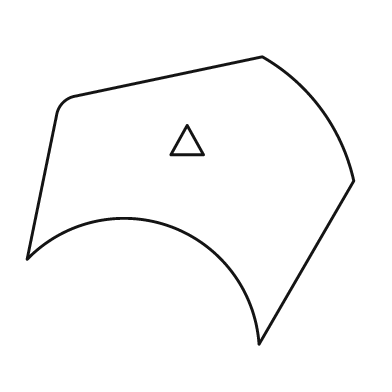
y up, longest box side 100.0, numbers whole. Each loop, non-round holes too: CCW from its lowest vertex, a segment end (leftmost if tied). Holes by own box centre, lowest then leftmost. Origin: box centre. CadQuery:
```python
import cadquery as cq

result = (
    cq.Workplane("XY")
    .moveTo(21.0, -44.0)
    .lineTo(50.0, 6.0)
    .threePointArc((40.0, 28.0), (22.0, 44.0))
    .lineTo(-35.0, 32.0)
    .threePointArc((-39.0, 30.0), (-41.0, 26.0))
    .lineTo(-50.0, -18.0)
    .threePointArc((-6.0, -8.0), (21.0, -44.0))
    .close()
    .moveTo(-6.0, 14.0)
    .lineTo(4.0, 14.0)
    .lineTo(-1.0, 23.0)
    .close()
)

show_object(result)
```